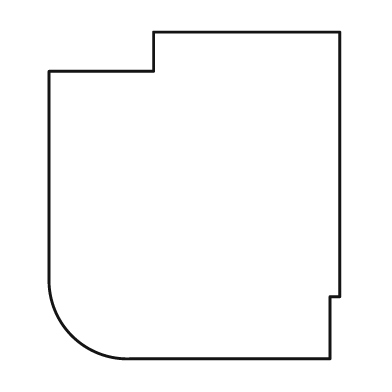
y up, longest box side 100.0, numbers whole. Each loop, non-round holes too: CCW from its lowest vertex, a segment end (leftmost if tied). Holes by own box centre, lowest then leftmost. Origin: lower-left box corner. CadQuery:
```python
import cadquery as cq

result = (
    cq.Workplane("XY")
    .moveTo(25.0, 0.0)
    .lineTo(86.0, 0.0)
    .lineTo(86.0, 19.0)
    .lineTo(89.0, 19.0)
    .lineTo(89.0, 100.0)
    .lineTo(32.0, 100.0)
    .lineTo(32.0, 88.0)
    .lineTo(0.0, 88.0)
    .lineTo(0.0, 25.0)
    .threePointArc((7.0, 7.0), (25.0, 0.0))
    .close()
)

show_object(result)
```